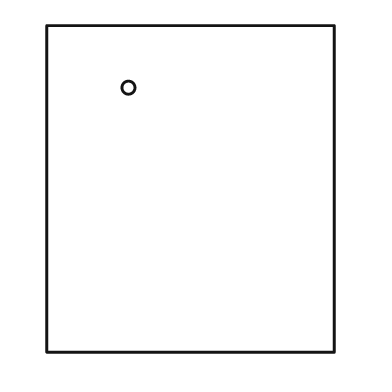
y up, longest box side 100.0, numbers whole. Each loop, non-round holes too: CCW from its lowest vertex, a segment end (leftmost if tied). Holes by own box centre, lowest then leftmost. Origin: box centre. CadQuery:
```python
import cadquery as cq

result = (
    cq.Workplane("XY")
    .moveTo(-44.0, -50.0)
    .lineTo(44.0, -50.0)
    .lineTo(44.0, 50.0)
    .lineTo(-44.0, 50.0)
    .close()
    .moveTo(-19.0, 31.0)
    .circle(2.0)
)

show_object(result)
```